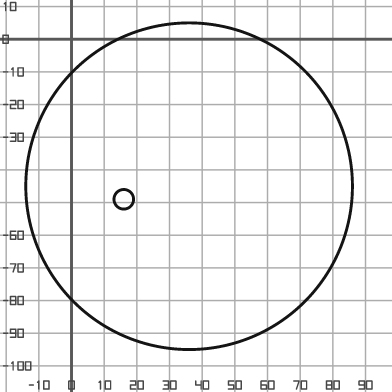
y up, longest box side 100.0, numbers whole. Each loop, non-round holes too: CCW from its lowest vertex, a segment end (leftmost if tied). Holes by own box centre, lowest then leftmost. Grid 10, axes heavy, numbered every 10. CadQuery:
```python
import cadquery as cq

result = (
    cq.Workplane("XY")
    .moveTo(36.0, -45.0)
    .circle(50.0)
    .moveTo(16.0, -49.0)
    .circle(3.0)
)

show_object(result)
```